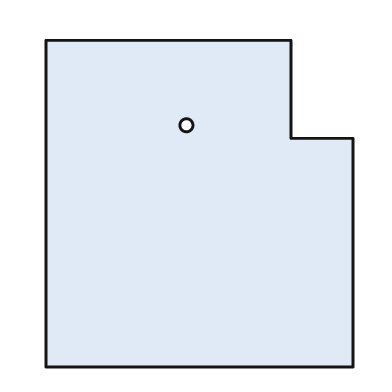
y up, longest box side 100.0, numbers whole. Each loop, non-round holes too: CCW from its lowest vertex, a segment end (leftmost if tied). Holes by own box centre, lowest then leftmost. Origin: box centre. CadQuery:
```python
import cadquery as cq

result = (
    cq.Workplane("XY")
    .moveTo(-47.0, -50.0)
    .lineTo(47.0, -50.0)
    .lineTo(47.0, 20.0)
    .lineTo(28.0, 20.0)
    .lineTo(28.0, 50.0)
    .lineTo(-47.0, 50.0)
    .close()
    .moveTo(-4.0, 24.0)
    .circle(2.0)
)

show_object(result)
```